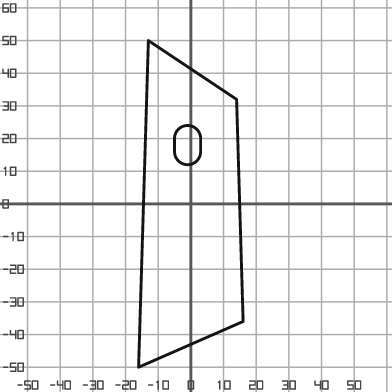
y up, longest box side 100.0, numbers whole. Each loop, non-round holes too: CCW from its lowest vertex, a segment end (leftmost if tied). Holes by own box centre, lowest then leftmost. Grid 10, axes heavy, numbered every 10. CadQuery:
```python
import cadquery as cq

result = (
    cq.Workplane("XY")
    .moveTo(-16.0, -50.0)
    .lineTo(16.0, -36.0)
    .lineTo(14.0, 32.0)
    .lineTo(-13.0, 50.0)
    .close()
    .moveTo(-5.0, 16.0)
    .threePointArc((-1.0, 12.0), (3.0, 16.0))
    .lineTo(3.0, 20.0)
    .threePointArc((-1.0, 24.0), (-5.0, 20.0))
    .close()
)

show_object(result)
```